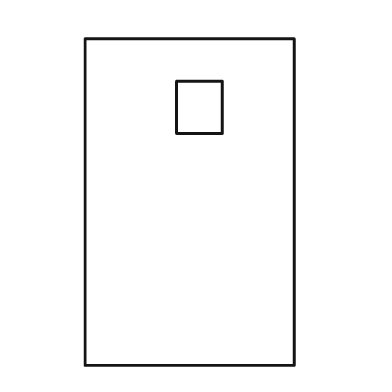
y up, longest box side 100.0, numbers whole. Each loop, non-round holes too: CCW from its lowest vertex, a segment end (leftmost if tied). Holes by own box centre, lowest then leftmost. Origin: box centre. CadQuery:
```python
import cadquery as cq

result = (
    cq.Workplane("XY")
    .moveTo(-32.0, -50.0)
    .lineTo(32.0, -50.0)
    .lineTo(32.0, 50.0)
    .lineTo(-32.0, 50.0)
    .close()
    .moveTo(-4.0, 21.0)
    .lineTo(10.0, 21.0)
    .lineTo(10.0, 37.0)
    .lineTo(-4.0, 37.0)
    .close()
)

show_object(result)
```